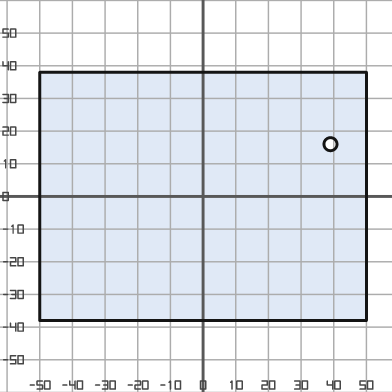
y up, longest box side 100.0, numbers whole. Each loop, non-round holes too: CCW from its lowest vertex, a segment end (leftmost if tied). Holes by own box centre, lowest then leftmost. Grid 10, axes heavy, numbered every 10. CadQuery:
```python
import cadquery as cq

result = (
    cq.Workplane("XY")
    .moveTo(-50.0, -38.0)
    .lineTo(50.0, -38.0)
    .lineTo(50.0, 38.0)
    .lineTo(-50.0, 38.0)
    .close()
    .moveTo(39.0, 16.0)
    .circle(2.0)
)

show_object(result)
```